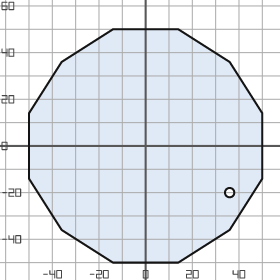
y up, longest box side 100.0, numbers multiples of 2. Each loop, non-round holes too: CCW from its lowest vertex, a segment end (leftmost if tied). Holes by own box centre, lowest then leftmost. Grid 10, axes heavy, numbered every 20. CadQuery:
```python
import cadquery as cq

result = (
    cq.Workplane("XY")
    .moveTo(-14.0, -50.0)
    .lineTo(14.0, -50.0)
    .lineTo(36.0, -36.0)
    .lineTo(50.0, -14.0)
    .lineTo(50.0, 14.0)
    .lineTo(36.0, 36.0)
    .lineTo(14.0, 50.0)
    .lineTo(-14.0, 50.0)
    .lineTo(-36.0, 36.0)
    .lineTo(-50.0, 14.0)
    .lineTo(-50.0, -14.0)
    .lineTo(-36.0, -36.0)
    .close()
    .moveTo(36.0, -20.0)
    .circle(2.0)
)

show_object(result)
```